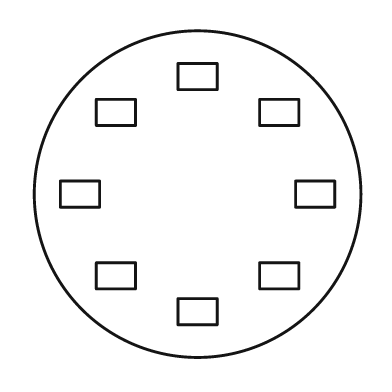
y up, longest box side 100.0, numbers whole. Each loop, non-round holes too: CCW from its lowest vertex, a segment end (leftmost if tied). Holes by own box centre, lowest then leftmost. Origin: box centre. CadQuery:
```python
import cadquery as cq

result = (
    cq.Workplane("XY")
    .moveTo(0.0, 0.0)
    .circle(50.0)
    .moveTo(-6.0, -40.0)
    .lineTo(6.0, -40.0)
    .lineTo(6.0, -32.0)
    .lineTo(-6.0, -32.0)
    .close()
    .moveTo(-31.0, -29.0)
    .lineTo(-19.0, -29.0)
    .lineTo(-19.0, -21.0)
    .lineTo(-31.0, -21.0)
    .close()
    .moveTo(19.0, -29.0)
    .lineTo(31.0, -29.0)
    .lineTo(31.0, -21.0)
    .lineTo(19.0, -21.0)
    .close()
    .moveTo(-42.0, -4.0)
    .lineTo(-30.0, -4.0)
    .lineTo(-30.0, 4.0)
    .lineTo(-42.0, 4.0)
    .close()
    .moveTo(30.0, -4.0)
    .lineTo(42.0, -4.0)
    .lineTo(42.0, 4.0)
    .lineTo(30.0, 4.0)
    .close()
    .moveTo(-31.0, 21.0)
    .lineTo(-19.0, 21.0)
    .lineTo(-19.0, 29.0)
    .lineTo(-31.0, 29.0)
    .close()
    .moveTo(19.0, 21.0)
    .lineTo(31.0, 21.0)
    .lineTo(31.0, 29.0)
    .lineTo(19.0, 29.0)
    .close()
    .moveTo(-6.0, 32.0)
    .lineTo(6.0, 32.0)
    .lineTo(6.0, 40.0)
    .lineTo(-6.0, 40.0)
    .close()
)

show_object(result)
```